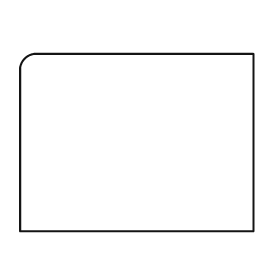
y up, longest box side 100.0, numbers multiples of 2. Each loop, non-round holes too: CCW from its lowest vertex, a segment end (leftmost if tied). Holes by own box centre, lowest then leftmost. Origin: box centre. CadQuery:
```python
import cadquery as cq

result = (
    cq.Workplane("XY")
    .moveTo(-50.0, -38.0)
    .lineTo(50.0, -38.0)
    .lineTo(50.0, 38.0)
    .lineTo(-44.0, 38.0)
    .threePointArc((-48.0, 36.0), (-50.0, 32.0))
    .close()
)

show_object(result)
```